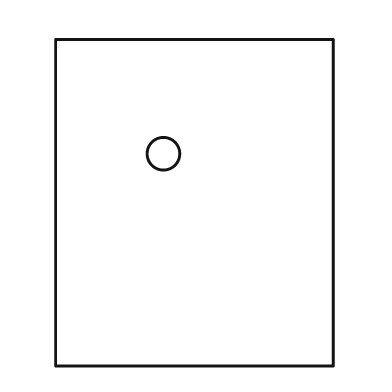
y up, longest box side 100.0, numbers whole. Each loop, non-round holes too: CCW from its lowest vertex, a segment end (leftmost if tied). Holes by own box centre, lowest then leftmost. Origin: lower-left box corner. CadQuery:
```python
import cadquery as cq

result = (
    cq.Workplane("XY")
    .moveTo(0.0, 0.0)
    .lineTo(85.0, 0.0)
    .lineTo(85.0, 100.0)
    .lineTo(0.0, 100.0)
    .close()
    .moveTo(33.0, 65.0)
    .circle(5.0)
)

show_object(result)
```